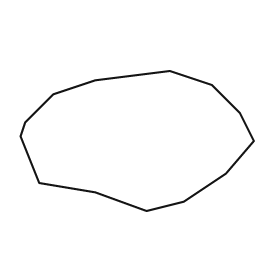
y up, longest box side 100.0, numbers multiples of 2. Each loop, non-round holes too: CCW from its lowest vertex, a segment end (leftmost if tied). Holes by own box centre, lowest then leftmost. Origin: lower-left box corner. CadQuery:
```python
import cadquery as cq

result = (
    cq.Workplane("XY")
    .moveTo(54.0, 0.0)
    .lineTo(70.0, 4.0)
    .lineTo(88.0, 16.0)
    .lineTo(100.0, 30.0)
    .lineTo(94.0, 42.0)
    .lineTo(82.0, 54.0)
    .lineTo(64.0, 60.0)
    .lineTo(32.0, 56.0)
    .lineTo(14.0, 50.0)
    .lineTo(2.0, 38.0)
    .lineTo(0.0, 32.0)
    .lineTo(8.0, 12.0)
    .lineTo(32.0, 8.0)
    .close()
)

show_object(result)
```